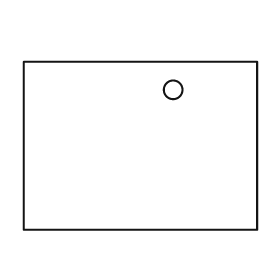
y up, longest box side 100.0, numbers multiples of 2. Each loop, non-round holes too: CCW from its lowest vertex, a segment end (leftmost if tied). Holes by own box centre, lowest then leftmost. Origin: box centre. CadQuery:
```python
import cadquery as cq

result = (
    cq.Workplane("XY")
    .moveTo(-50.0, -36.0)
    .lineTo(50.0, -36.0)
    .lineTo(50.0, 36.0)
    .lineTo(-50.0, 36.0)
    .close()
    .moveTo(14.0, 24.0)
    .circle(4.0)
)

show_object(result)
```